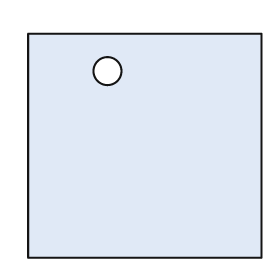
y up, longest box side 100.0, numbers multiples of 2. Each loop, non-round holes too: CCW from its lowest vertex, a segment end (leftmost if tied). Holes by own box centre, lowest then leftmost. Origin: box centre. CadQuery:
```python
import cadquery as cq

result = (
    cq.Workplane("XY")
    .moveTo(-50.0, -48.0)
    .lineTo(50.0, -48.0)
    .lineTo(50.0, 48.0)
    .lineTo(-50.0, 48.0)
    .close()
    .moveTo(-16.0, 32.0)
    .circle(6.0)
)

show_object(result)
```